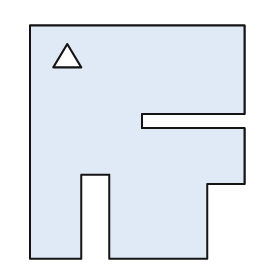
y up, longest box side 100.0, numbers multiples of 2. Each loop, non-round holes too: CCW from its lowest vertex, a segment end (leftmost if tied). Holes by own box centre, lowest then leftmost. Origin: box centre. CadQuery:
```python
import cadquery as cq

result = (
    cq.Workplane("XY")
    .moveTo(-46.0, -50.0)
    .lineTo(-24.0, -50.0)
    .lineTo(-24.0, -14.0)
    .lineTo(-12.0, -14.0)
    .lineTo(-12.0, -50.0)
    .lineTo(30.0, -50.0)
    .lineTo(30.0, -18.0)
    .lineTo(46.0, -18.0)
    .lineTo(46.0, 6.0)
    .lineTo(2.0, 6.0)
    .lineTo(2.0, 12.0)
    .lineTo(46.0, 12.0)
    .lineTo(46.0, 50.0)
    .lineTo(-46.0, 50.0)
    .close()
    .moveTo(-36.0, 32.0)
    .lineTo(-24.0, 32.0)
    .lineTo(-30.0, 42.0)
    .close()
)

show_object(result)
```